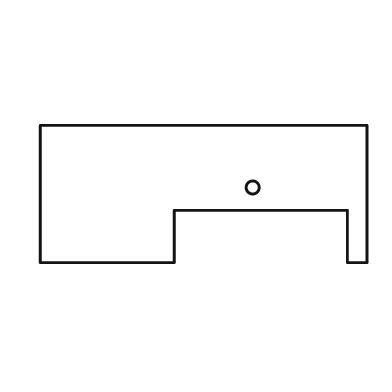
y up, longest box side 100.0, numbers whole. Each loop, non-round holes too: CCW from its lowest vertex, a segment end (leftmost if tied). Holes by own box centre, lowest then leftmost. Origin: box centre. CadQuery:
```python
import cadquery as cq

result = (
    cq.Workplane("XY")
    .moveTo(-50.0, -21.0)
    .lineTo(-9.0, -21.0)
    .lineTo(-9.0, -5.0)
    .lineTo(44.0, -5.0)
    .lineTo(44.0, -21.0)
    .lineTo(50.0, -21.0)
    .lineTo(50.0, 21.0)
    .lineTo(-50.0, 21.0)
    .close()
    .moveTo(15.0, 2.0)
    .circle(2.0)
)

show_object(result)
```